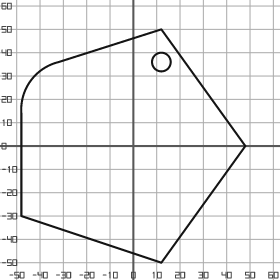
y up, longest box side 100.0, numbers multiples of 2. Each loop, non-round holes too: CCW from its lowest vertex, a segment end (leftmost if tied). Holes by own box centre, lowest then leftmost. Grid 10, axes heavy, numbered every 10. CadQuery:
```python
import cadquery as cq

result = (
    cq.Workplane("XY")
    .moveTo(12.0, -50.0)
    .lineTo(48.0, 0.0)
    .lineTo(12.0, 50.0)
    .lineTo(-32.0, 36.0)
    .threePointArc((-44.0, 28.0), (-48.0, 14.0))
    .lineTo(-48.0, -30.0)
    .close()
    .moveTo(12.0, 36.0)
    .circle(4.0)
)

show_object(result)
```